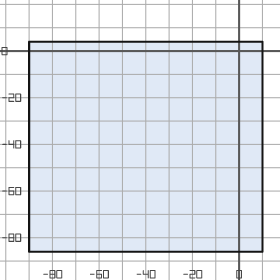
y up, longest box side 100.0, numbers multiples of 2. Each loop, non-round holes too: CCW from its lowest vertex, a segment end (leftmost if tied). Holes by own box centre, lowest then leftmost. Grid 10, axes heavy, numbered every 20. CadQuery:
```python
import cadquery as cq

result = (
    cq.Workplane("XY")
    .moveTo(-90.0, -86.0)
    .lineTo(10.0, -86.0)
    .lineTo(10.0, 4.0)
    .lineTo(-90.0, 4.0)
    .close()
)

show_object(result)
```